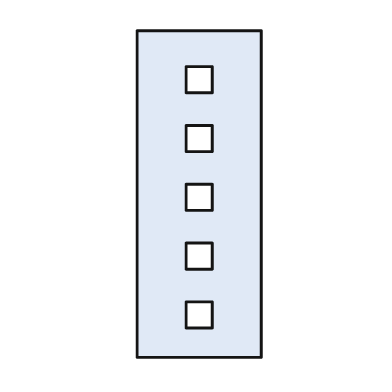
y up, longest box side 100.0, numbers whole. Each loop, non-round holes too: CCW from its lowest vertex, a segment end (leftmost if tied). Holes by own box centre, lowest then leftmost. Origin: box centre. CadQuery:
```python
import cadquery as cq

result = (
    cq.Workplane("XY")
    .moveTo(-19.0, -50.0)
    .lineTo(19.0, -50.0)
    .lineTo(19.0, 50.0)
    .lineTo(-19.0, 50.0)
    .close()
    .moveTo(-4.0, -41.0)
    .lineTo(4.0, -41.0)
    .lineTo(4.0, -33.0)
    .lineTo(-4.0, -33.0)
    .close()
    .moveTo(-4.0, -23.0)
    .lineTo(4.0, -23.0)
    .lineTo(4.0, -15.0)
    .lineTo(-4.0, -15.0)
    .close()
    .moveTo(-4.0, -5.0)
    .lineTo(4.0, -5.0)
    .lineTo(4.0, 3.0)
    .lineTo(-4.0, 3.0)
    .close()
    .moveTo(-4.0, 13.0)
    .lineTo(4.0, 13.0)
    .lineTo(4.0, 21.0)
    .lineTo(-4.0, 21.0)
    .close()
    .moveTo(-4.0, 31.0)
    .lineTo(4.0, 31.0)
    .lineTo(4.0, 39.0)
    .lineTo(-4.0, 39.0)
    .close()
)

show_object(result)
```